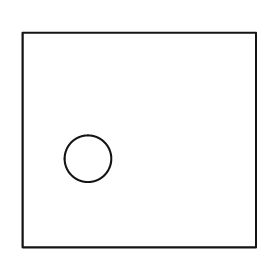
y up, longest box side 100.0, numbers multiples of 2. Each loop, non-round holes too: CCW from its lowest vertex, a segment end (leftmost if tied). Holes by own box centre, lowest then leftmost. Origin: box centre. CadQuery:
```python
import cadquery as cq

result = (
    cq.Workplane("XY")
    .moveTo(-50.0, -46.0)
    .lineTo(50.0, -46.0)
    .lineTo(50.0, 46.0)
    .lineTo(-50.0, 46.0)
    .close()
    .moveTo(-22.0, -8.0)
    .circle(10.0)
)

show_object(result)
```